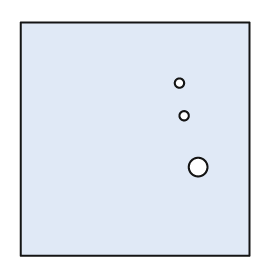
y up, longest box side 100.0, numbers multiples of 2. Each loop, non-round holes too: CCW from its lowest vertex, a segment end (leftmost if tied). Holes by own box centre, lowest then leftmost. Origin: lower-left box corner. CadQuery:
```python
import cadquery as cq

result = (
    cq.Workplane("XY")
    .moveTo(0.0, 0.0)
    .lineTo(98.0, 0.0)
    .lineTo(98.0, 100.0)
    .lineTo(0.0, 100.0)
    .close()
    .moveTo(76.0, 38.0)
    .circle(4.0)
    .moveTo(70.0, 60.0)
    .circle(2.0)
    .moveTo(68.0, 74.0)
    .circle(2.0)
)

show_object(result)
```